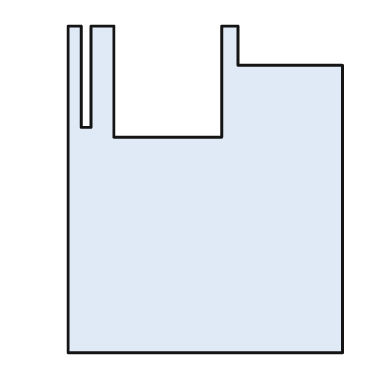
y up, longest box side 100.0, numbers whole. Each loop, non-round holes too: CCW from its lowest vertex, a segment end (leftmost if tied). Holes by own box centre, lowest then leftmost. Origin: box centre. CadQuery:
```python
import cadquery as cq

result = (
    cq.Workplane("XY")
    .moveTo(-42.0, -50.0)
    .lineTo(42.0, -50.0)
    .lineTo(42.0, 38.0)
    .lineTo(10.0, 38.0)
    .lineTo(10.0, 50.0)
    .lineTo(5.0, 50.0)
    .lineTo(5.0, 16.0)
    .lineTo(-28.0, 16.0)
    .lineTo(-28.0, 50.0)
    .lineTo(-35.0, 50.0)
    .lineTo(-35.0, 19.0)
    .lineTo(-38.0, 19.0)
    .lineTo(-38.0, 50.0)
    .lineTo(-42.0, 50.0)
    .close()
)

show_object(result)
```